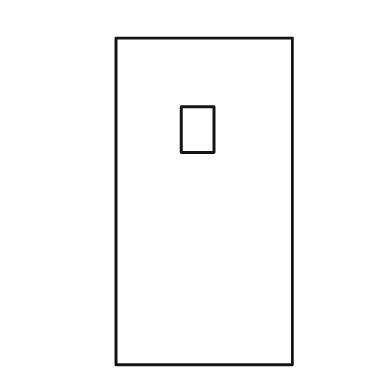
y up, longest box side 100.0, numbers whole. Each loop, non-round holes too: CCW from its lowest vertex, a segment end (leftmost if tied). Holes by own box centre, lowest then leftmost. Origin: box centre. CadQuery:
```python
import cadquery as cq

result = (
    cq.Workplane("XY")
    .moveTo(-27.0, -50.0)
    .lineTo(27.0, -50.0)
    .lineTo(27.0, 50.0)
    .lineTo(-27.0, 50.0)
    .close()
    .moveTo(-7.0, 15.0)
    .lineTo(3.0, 15.0)
    .lineTo(3.0, 29.0)
    .lineTo(-7.0, 29.0)
    .close()
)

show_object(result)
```